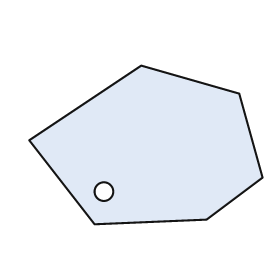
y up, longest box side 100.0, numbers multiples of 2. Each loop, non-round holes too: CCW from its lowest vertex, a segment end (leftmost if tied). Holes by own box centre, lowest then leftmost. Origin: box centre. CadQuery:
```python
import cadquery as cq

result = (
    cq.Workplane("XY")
    .moveTo(-22.0, -34.0)
    .lineTo(26.0, -32.0)
    .lineTo(50.0, -14.0)
    .lineTo(40.0, 22.0)
    .lineTo(-2.0, 34.0)
    .lineTo(-50.0, 2.0)
    .close()
    .moveTo(-18.0, -20.0)
    .circle(4.0)
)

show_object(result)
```